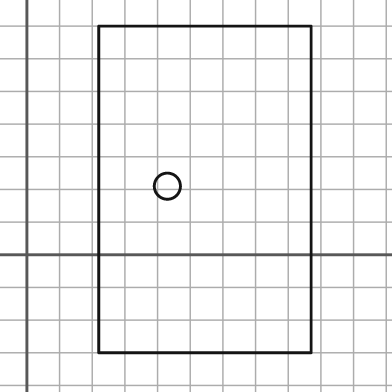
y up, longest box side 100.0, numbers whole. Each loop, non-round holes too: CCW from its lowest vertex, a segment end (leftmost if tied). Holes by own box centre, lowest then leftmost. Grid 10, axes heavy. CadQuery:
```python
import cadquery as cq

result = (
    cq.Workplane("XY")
    .moveTo(22.0, -30.0)
    .lineTo(87.0, -30.0)
    .lineTo(87.0, 70.0)
    .lineTo(22.0, 70.0)
    .close()
    .moveTo(43.0, 21.0)
    .circle(4.0)
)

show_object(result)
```